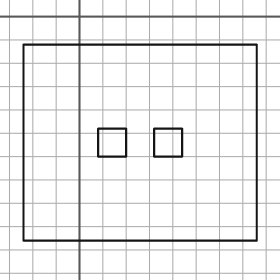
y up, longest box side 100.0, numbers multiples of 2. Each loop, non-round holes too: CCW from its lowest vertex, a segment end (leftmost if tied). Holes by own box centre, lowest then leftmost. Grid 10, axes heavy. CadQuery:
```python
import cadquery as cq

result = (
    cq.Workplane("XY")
    .moveTo(-24.0, -96.0)
    .lineTo(76.0, -96.0)
    .lineTo(76.0, -12.0)
    .lineTo(-24.0, -12.0)
    .close()
    .moveTo(8.0, -60.0)
    .lineTo(20.0, -60.0)
    .lineTo(20.0, -48.0)
    .lineTo(8.0, -48.0)
    .close()
    .moveTo(32.0, -60.0)
    .lineTo(44.0, -60.0)
    .lineTo(44.0, -48.0)
    .lineTo(32.0, -48.0)
    .close()
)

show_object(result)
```